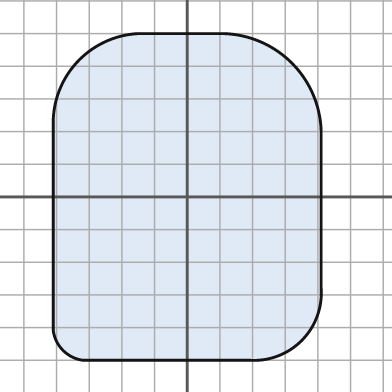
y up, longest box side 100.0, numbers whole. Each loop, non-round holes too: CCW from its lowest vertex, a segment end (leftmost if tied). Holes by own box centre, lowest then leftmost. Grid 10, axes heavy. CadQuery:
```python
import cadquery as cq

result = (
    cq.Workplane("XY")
    .moveTo(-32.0, -50.0)
    .lineTo(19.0, -50.0)
    .threePointArc((35.0, -44.0), (41.0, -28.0))
    .lineTo(41.0, 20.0)
    .threePointArc((32.0, 41.0), (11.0, 50.0))
    .lineTo(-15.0, 50.0)
    .threePointArc((-33.0, 42.0), (-41.0, 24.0))
    .lineTo(-41.0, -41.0)
    .threePointArc((-38.0, -47.0), (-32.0, -50.0))
    .close()
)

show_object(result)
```